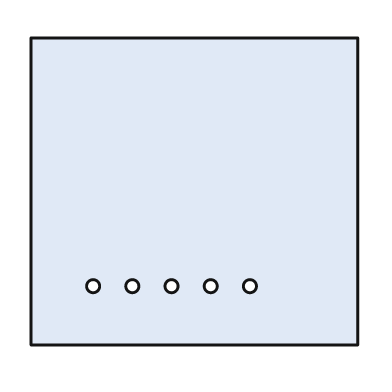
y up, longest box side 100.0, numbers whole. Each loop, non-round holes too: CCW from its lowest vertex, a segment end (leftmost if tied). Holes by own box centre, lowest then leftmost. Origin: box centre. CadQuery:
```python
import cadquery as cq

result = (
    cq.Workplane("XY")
    .moveTo(-50.0, -47.0)
    .lineTo(50.0, -47.0)
    .lineTo(50.0, 47.0)
    .lineTo(-50.0, 47.0)
    .close()
    .moveTo(-31.0, -29.0)
    .circle(2.0)
    .moveTo(-19.0, -29.0)
    .circle(2.0)
    .moveTo(-7.0, -29.0)
    .circle(2.0)
    .moveTo(5.0, -29.0)
    .circle(2.0)
    .moveTo(17.0, -29.0)
    .circle(2.0)
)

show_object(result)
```